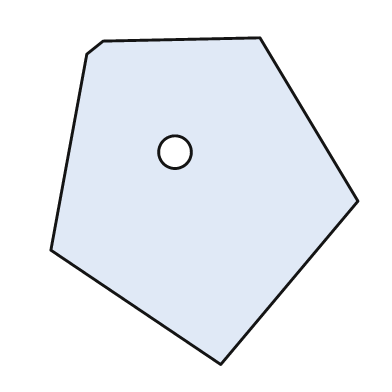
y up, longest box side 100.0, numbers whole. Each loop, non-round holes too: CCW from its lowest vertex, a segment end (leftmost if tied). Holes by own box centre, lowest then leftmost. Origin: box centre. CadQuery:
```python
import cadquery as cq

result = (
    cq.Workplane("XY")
    .moveTo(5.0, -50.0)
    .lineTo(47.0, 0.0)
    .lineTo(17.0, 50.0)
    .lineTo(-31.0, 49.0)
    .lineTo(-36.0, 45.0)
    .lineTo(-47.0, -15.0)
    .close()
    .moveTo(-9.0, 15.0)
    .circle(5.0)
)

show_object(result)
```